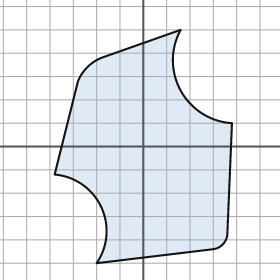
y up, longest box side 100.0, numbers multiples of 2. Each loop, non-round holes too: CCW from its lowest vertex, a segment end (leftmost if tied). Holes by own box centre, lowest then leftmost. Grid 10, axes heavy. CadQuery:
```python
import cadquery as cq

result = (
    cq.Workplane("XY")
    .moveTo(-20.0, -50.0)
    .lineTo(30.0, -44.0)
    .threePointArc((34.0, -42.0), (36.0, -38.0))
    .lineTo(38.0, 10.0)
    .threePointArc((16.0, 24.0), (16.0, 50.0))
    .lineTo(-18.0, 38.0)
    .threePointArc((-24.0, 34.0), (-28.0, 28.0))
    .lineTo(-38.0, -12.0)
    .threePointArc((-18.0, -26.0), (-20.0, -50.0))
    .close()
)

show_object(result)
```